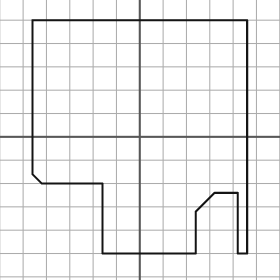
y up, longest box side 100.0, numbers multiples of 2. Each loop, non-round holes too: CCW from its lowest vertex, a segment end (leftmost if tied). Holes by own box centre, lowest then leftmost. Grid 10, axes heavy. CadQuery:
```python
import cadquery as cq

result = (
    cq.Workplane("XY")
    .moveTo(-16.0, -50.0)
    .lineTo(24.0, -50.0)
    .lineTo(24.0, -32.0)
    .lineTo(32.0, -24.0)
    .lineTo(42.0, -24.0)
    .lineTo(42.0, -50.0)
    .lineTo(46.0, -50.0)
    .lineTo(46.0, 50.0)
    .lineTo(-46.0, 50.0)
    .lineTo(-46.0, -16.0)
    .lineTo(-42.0, -20.0)
    .lineTo(-16.0, -20.0)
    .close()
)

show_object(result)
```